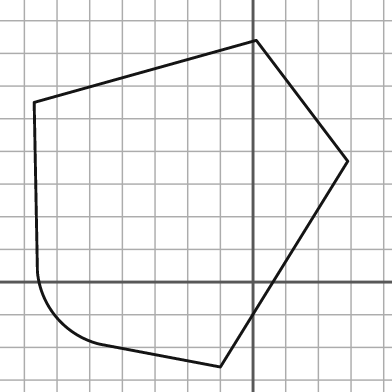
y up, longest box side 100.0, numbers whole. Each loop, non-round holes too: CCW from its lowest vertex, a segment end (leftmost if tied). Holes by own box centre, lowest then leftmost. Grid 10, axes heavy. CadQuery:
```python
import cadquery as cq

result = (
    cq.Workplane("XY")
    .moveTo(-10.0, -26.0)
    .lineTo(29.0, 37.0)
    .lineTo(1.0, 74.0)
    .lineTo(-67.0, 55.0)
    .lineTo(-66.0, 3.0)
    .threePointArc((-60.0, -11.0), (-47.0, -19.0))
    .close()
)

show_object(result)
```